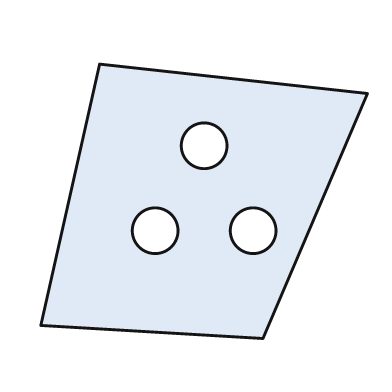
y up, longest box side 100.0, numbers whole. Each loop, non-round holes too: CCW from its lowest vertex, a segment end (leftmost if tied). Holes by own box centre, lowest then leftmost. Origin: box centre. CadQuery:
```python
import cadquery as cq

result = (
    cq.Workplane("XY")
    .moveTo(18.0, -42.0)
    .lineTo(50.0, 33.0)
    .lineTo(-32.0, 42.0)
    .lineTo(-50.0, -38.0)
    .close()
    .moveTo(-15.0, -9.0)
    .circle(7.0)
    .moveTo(15.0, -9.0)
    .circle(7.0)
    .moveTo(0.0, 17.0)
    .circle(7.0)
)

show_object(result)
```